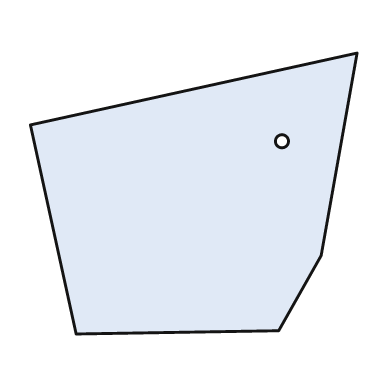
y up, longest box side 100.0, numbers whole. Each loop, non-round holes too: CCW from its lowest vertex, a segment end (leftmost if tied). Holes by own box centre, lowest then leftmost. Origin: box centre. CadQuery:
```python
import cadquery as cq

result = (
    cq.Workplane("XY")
    .moveTo(-36.0, -43.0)
    .lineTo(26.0, -42.0)
    .lineTo(39.0, -19.0)
    .lineTo(50.0, 43.0)
    .lineTo(-50.0, 21.0)
    .close()
    .moveTo(27.0, 16.0)
    .circle(2.0)
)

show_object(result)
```